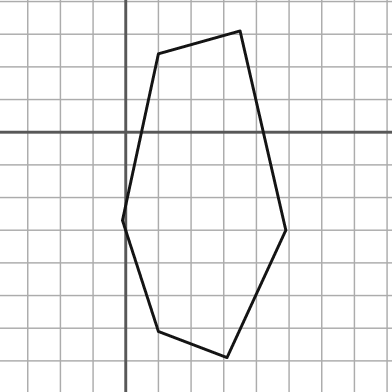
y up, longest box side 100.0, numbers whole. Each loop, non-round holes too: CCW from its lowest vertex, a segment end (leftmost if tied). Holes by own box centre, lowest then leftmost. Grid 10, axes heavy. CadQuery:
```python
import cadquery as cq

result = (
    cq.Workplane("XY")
    .moveTo(31.0, -69.0)
    .lineTo(49.0, -30.0)
    .lineTo(35.0, 31.0)
    .lineTo(10.0, 24.0)
    .lineTo(-1.0, -27.0)
    .lineTo(10.0, -61.0)
    .close()
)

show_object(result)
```